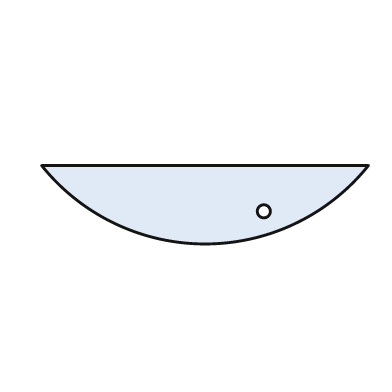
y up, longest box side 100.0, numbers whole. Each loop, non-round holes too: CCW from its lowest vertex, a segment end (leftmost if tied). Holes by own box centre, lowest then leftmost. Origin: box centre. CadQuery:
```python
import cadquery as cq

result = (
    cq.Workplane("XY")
    .moveTo(-50.0, 12.0)
    .threePointArc((0.0, -12.0), (50.0, 12.0))
    .close()
    .moveTo(18.0, -2.0)
    .circle(2.0)
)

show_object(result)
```